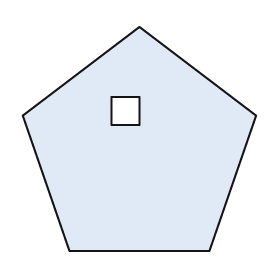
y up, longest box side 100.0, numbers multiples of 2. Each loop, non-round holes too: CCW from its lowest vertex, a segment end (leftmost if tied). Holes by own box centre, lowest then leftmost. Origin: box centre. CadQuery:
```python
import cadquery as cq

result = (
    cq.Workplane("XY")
    .moveTo(-30.0, -48.0)
    .lineTo(30.0, -48.0)
    .lineTo(50.0, 10.0)
    .lineTo(0.0, 48.0)
    .lineTo(-50.0, 10.0)
    .close()
    .moveTo(-12.0, 6.0)
    .lineTo(0.0, 6.0)
    .lineTo(0.0, 18.0)
    .lineTo(-12.0, 18.0)
    .close()
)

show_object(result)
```